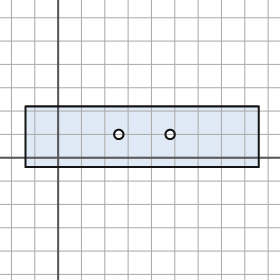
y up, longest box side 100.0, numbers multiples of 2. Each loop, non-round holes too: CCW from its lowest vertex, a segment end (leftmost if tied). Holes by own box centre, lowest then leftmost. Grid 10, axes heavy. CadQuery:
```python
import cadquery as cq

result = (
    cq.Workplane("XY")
    .moveTo(-14.0, -4.0)
    .lineTo(86.0, -4.0)
    .lineTo(86.0, 22.0)
    .lineTo(-14.0, 22.0)
    .close()
    .moveTo(26.0, 10.0)
    .circle(2.0)
    .moveTo(48.0, 10.0)
    .circle(2.0)
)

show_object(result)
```